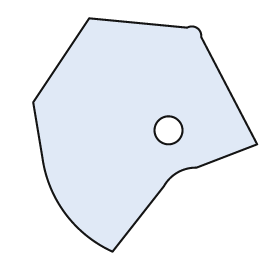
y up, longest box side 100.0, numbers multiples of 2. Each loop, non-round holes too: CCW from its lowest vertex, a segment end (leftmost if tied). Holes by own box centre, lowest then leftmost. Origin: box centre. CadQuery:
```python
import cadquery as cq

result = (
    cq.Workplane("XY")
    .moveTo(-14.0, -50.0)
    .lineTo(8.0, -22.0)
    .threePointArc((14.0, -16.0), (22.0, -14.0))
    .lineTo(48.0, -4.0)
    .lineTo(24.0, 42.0)
    .threePointArc((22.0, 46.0), (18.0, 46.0))
    .lineTo(-24.0, 50.0)
    .lineTo(-48.0, 14.0)
    .lineTo(-44.0, -10.0)
    .threePointArc((-34.0, -34.0), (-14.0, -50.0))
    .close()
    .moveTo(10.0, 2.0)
    .circle(6.0)
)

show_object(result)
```